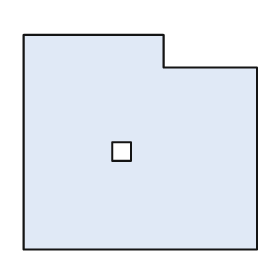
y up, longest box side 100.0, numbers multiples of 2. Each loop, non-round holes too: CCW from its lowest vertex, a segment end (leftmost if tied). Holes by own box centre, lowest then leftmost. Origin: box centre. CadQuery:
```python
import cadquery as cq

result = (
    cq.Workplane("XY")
    .moveTo(-50.0, -46.0)
    .lineTo(50.0, -46.0)
    .lineTo(50.0, 32.0)
    .lineTo(10.0, 32.0)
    .lineTo(10.0, 46.0)
    .lineTo(-50.0, 46.0)
    .close()
    .moveTo(-12.0, -8.0)
    .lineTo(-4.0, -8.0)
    .lineTo(-4.0, 0.0)
    .lineTo(-12.0, 0.0)
    .close()
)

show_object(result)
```